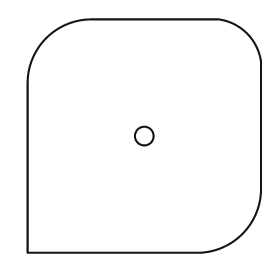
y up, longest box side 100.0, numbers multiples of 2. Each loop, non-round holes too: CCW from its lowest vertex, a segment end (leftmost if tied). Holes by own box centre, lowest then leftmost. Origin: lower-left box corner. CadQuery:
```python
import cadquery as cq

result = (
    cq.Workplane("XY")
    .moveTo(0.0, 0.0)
    .lineTo(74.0, 0.0)
    .threePointArc((92.0, 8.0), (100.0, 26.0))
    .lineTo(100.0, 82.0)
    .threePointArc((94.0, 94.0), (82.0, 100.0))
    .lineTo(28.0, 100.0)
    .threePointArc((8.0, 92.0), (0.0, 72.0))
    .close()
    .moveTo(50.0, 50.0)
    .circle(4.0)
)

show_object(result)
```